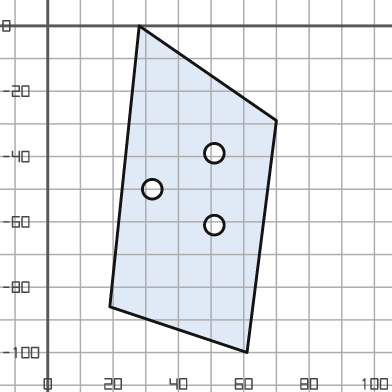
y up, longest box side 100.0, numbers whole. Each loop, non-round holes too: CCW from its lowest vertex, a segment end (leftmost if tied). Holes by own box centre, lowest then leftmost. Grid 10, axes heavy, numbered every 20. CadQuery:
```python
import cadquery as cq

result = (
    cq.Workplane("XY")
    .moveTo(61.0, -100.0)
    .lineTo(70.0, -29.0)
    .lineTo(28.0, 0.0)
    .lineTo(19.0, -86.0)
    .close()
    .moveTo(51.0, -61.0)
    .circle(3.0)
    .moveTo(32.0, -50.0)
    .circle(3.0)
    .moveTo(51.0, -39.0)
    .circle(3.0)
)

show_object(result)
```